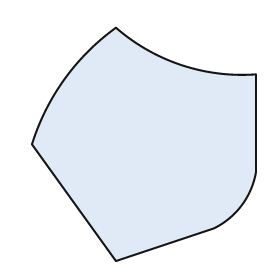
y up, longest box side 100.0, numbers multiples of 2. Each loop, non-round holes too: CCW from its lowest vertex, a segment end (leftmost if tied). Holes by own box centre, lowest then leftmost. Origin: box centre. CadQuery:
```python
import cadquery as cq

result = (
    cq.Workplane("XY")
    .moveTo(-12.0, -50.0)
    .lineTo(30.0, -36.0)
    .threePointArc((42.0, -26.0), (48.0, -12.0))
    .lineTo(48.0, 30.0)
    .threePointArc((16.0, 34.0), (-12.0, 50.0))
    .threePointArc((-34.0, 28.0), (-48.0, 0.0))
    .close()
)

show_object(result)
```